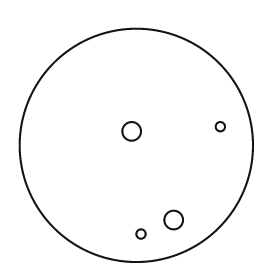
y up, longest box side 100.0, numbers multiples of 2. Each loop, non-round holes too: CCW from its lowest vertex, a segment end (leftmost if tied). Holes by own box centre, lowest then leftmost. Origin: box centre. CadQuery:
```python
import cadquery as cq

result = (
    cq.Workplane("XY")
    .moveTo(0.0, 0.0)
    .circle(50.0)
    .moveTo(2.0, -38.0)
    .circle(2.0)
    .moveTo(16.0, -32.0)
    .circle(4.0)
    .moveTo(-2.0, 6.0)
    .circle(4.0)
    .moveTo(36.0, 8.0)
    .circle(2.0)
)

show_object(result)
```